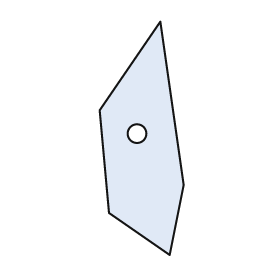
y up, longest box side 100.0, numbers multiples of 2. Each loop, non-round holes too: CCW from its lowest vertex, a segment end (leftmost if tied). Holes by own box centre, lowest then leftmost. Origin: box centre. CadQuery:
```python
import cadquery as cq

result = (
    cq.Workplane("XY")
    .moveTo(12.0, -50.0)
    .lineTo(18.0, -20.0)
    .lineTo(8.0, 50.0)
    .lineTo(-18.0, 12.0)
    .lineTo(-14.0, -32.0)
    .close()
    .moveTo(-2.0, 2.0)
    .circle(4.0)
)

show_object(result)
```